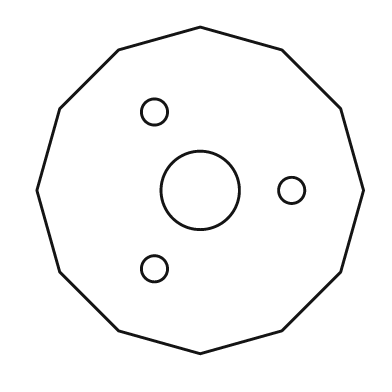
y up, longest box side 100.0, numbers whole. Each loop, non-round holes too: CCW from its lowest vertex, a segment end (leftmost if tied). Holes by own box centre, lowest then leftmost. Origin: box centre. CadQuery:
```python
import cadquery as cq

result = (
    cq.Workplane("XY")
    .moveTo(0.0, -50.0)
    .lineTo(25.0, -43.0)
    .lineTo(43.0, -25.0)
    .lineTo(50.0, 0.0)
    .lineTo(43.0, 25.0)
    .lineTo(25.0, 43.0)
    .lineTo(0.0, 50.0)
    .lineTo(-25.0, 43.0)
    .lineTo(-43.0, 25.0)
    .lineTo(-50.0, 0.0)
    .lineTo(-43.0, -25.0)
    .lineTo(-25.0, -43.0)
    .close()
    .moveTo(-14.0, -24.0)
    .circle(4.0)
    .moveTo(0.0, 0.0)
    .circle(12.0)
    .moveTo(28.0, 0.0)
    .circle(4.0)
    .moveTo(-14.0, 24.0)
    .circle(4.0)
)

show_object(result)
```